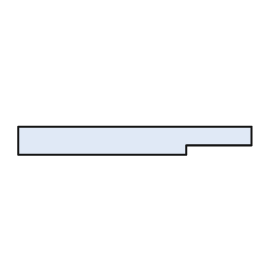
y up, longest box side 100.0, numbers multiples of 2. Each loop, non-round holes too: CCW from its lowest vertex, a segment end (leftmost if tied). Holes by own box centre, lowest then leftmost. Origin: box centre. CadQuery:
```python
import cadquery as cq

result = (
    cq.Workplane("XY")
    .moveTo(-50.0, -6.0)
    .lineTo(22.0, -6.0)
    .lineTo(22.0, -2.0)
    .lineTo(50.0, -2.0)
    .lineTo(50.0, 6.0)
    .lineTo(-50.0, 6.0)
    .close()
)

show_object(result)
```